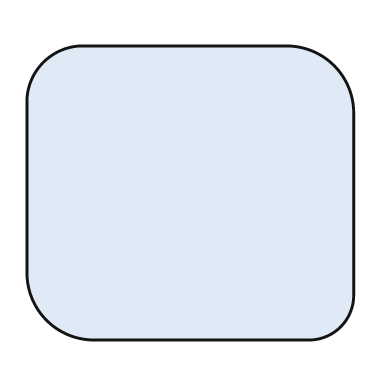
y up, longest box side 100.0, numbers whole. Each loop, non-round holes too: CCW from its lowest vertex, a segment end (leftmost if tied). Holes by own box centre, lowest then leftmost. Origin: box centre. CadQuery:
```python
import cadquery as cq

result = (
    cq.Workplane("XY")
    .moveTo(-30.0, -45.0)
    .lineTo(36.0, -45.0)
    .threePointArc((46.0, -41.0), (50.0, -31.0))
    .lineTo(50.0, 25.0)
    .threePointArc((44.0, 39.0), (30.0, 45.0))
    .lineTo(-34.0, 45.0)
    .threePointArc((-45.0, 40.0), (-50.0, 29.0))
    .lineTo(-50.0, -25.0)
    .threePointArc((-44.0, -39.0), (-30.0, -45.0))
    .close()
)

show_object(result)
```